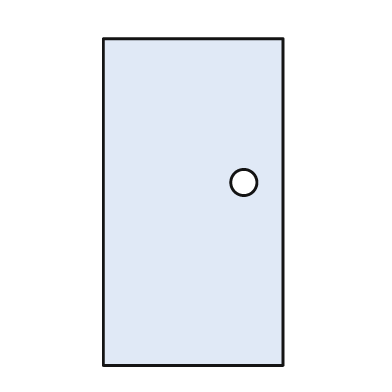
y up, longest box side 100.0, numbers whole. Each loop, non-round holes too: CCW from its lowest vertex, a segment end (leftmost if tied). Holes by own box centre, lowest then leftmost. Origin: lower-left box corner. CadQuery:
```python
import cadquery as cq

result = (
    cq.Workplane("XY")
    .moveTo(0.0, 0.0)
    .lineTo(55.0, 0.0)
    .lineTo(55.0, 100.0)
    .lineTo(0.0, 100.0)
    .close()
    .moveTo(43.0, 56.0)
    .circle(4.0)
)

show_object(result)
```